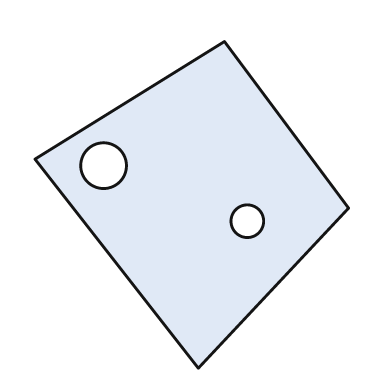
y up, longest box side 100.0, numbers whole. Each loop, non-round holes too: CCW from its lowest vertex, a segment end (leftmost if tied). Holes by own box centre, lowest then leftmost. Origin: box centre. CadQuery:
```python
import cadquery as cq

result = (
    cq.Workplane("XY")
    .moveTo(2.0, -50.0)
    .lineTo(48.0, -1.0)
    .lineTo(10.0, 50.0)
    .lineTo(-48.0, 14.0)
    .close()
    .moveTo(17.0, -5.0)
    .circle(5.0)
    .moveTo(-27.0, 12.0)
    .circle(7.0)
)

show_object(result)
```